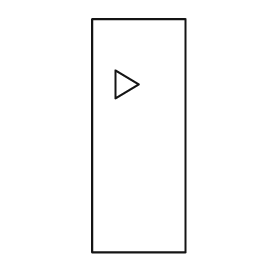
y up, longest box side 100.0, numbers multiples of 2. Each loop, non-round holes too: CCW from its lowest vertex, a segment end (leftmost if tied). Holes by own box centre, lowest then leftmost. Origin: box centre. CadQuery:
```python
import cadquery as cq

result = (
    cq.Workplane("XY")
    .moveTo(-20.0, -50.0)
    .lineTo(20.0, -50.0)
    .lineTo(20.0, 50.0)
    .lineTo(-20.0, 50.0)
    .close()
    .moveTo(-10.0, 16.0)
    .lineTo(0.0, 22.0)
    .lineTo(-10.0, 28.0)
    .close()
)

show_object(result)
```